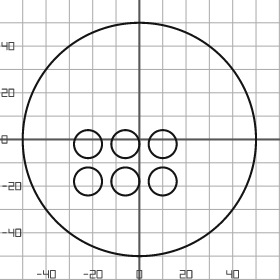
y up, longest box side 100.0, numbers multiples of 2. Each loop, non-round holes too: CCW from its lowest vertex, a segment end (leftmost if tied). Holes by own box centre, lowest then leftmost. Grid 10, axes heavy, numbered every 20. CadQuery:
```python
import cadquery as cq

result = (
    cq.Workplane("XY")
    .moveTo(0.0, 0.0)
    .circle(50.0)
    .moveTo(-22.0, -18.0)
    .circle(6.0)
    .moveTo(-6.0, -18.0)
    .circle(6.0)
    .moveTo(10.0, -18.0)
    .circle(6.0)
    .moveTo(-22.0, -2.0)
    .circle(6.0)
    .moveTo(-6.0, -2.0)
    .circle(6.0)
    .moveTo(10.0, -2.0)
    .circle(6.0)
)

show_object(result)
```